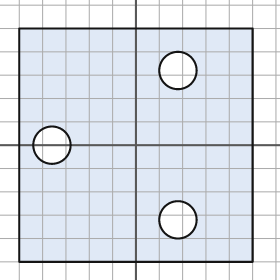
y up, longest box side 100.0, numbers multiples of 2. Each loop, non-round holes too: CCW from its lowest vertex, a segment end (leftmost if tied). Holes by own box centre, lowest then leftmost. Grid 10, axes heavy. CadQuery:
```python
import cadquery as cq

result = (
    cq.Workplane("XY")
    .moveTo(-50.0, -50.0)
    .lineTo(50.0, -50.0)
    .lineTo(50.0, 50.0)
    .lineTo(-50.0, 50.0)
    .close()
    .moveTo(18.0, -32.0)
    .circle(8.0)
    .moveTo(-36.0, 0.0)
    .circle(8.0)
    .moveTo(18.0, 32.0)
    .circle(8.0)
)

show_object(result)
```